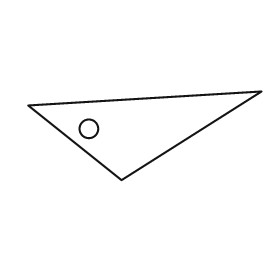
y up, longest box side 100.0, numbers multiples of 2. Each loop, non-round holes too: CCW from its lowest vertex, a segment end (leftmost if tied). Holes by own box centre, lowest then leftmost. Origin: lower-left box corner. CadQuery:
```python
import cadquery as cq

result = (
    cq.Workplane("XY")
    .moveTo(40.0, 0.0)
    .lineTo(100.0, 38.0)
    .lineTo(0.0, 32.0)
    .close()
    .moveTo(26.0, 22.0)
    .circle(4.0)
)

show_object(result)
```